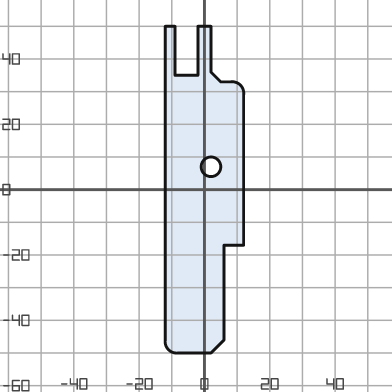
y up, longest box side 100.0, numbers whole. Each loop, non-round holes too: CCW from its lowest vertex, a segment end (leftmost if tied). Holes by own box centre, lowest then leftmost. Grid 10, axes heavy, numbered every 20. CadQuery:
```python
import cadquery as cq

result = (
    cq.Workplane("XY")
    .moveTo(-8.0, -50.0)
    .lineTo(2.0, -50.0)
    .lineTo(6.0, -46.0)
    .lineTo(6.0, -17.0)
    .lineTo(12.0, -17.0)
    .lineTo(12.0, 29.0)
    .threePointArc((11.0, 32.0), (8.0, 33.0))
    .lineTo(5.0, 33.0)
    .lineTo(2.0, 36.0)
    .lineTo(2.0, 50.0)
    .lineTo(-2.0, 50.0)
    .lineTo(-2.0, 35.0)
    .lineTo(-9.0, 35.0)
    .lineTo(-9.0, 50.0)
    .lineTo(-12.0, 50.0)
    .lineTo(-12.0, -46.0)
    .threePointArc((-11.0, -49.0), (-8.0, -50.0))
    .close()
    .moveTo(2.0, 7.0)
    .circle(3.0)
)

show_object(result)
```